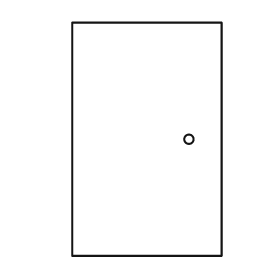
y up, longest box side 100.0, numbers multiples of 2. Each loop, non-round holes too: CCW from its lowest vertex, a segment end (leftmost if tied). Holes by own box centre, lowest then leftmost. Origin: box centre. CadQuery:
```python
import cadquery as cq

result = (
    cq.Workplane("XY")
    .moveTo(-32.0, -50.0)
    .lineTo(32.0, -50.0)
    .lineTo(32.0, 50.0)
    .lineTo(-32.0, 50.0)
    .close()
    .moveTo(18.0, 0.0)
    .circle(2.0)
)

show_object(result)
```